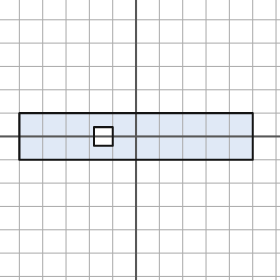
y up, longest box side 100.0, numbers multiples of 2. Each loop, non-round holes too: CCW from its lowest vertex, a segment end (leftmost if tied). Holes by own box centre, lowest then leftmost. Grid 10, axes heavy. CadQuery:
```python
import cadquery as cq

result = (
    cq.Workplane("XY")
    .moveTo(-50.0, -10.0)
    .lineTo(50.0, -10.0)
    .lineTo(50.0, 10.0)
    .lineTo(-50.0, 10.0)
    .close()
    .moveTo(-18.0, -4.0)
    .lineTo(-10.0, -4.0)
    .lineTo(-10.0, 4.0)
    .lineTo(-18.0, 4.0)
    .close()
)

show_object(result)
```